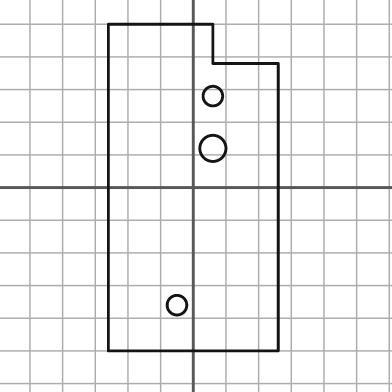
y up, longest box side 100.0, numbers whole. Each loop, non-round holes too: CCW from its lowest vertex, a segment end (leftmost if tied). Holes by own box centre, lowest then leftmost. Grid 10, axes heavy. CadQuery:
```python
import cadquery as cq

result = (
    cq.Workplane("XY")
    .moveTo(-26.0, -50.0)
    .lineTo(26.0, -50.0)
    .lineTo(26.0, 38.0)
    .lineTo(6.0, 38.0)
    .lineTo(6.0, 50.0)
    .lineTo(-26.0, 50.0)
    .close()
    .moveTo(-5.0, -36.0)
    .circle(3.0)
    .moveTo(6.0, 12.0)
    .circle(4.0)
    .moveTo(6.0, 28.0)
    .circle(3.0)
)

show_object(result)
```